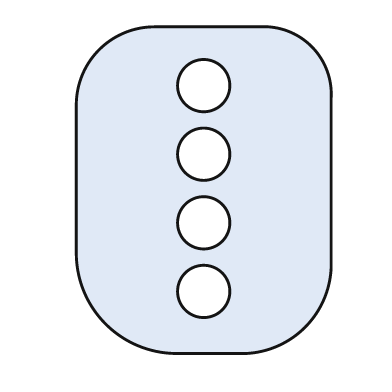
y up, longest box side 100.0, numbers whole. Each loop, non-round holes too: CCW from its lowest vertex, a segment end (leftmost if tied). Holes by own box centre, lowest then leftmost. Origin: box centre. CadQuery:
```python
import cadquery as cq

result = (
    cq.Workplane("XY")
    .moveTo(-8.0, -50.0)
    .lineTo(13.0, -50.0)
    .threePointArc((31.0, -42.0), (39.0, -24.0))
    .lineTo(39.0, 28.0)
    .threePointArc((33.0, 44.0), (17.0, 50.0))
    .lineTo(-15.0, 50.0)
    .threePointArc((-32.0, 43.0), (-39.0, 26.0))
    .lineTo(-39.0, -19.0)
    .threePointArc((-30.0, -41.0), (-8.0, -50.0))
    .close()
    .moveTo(0.0, -31.0)
    .circle(8.0)
    .moveTo(0.0, -10.0)
    .circle(8.0)
    .moveTo(0.0, 11.0)
    .circle(8.0)
    .moveTo(0.0, 32.0)
    .circle(8.0)
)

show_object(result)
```